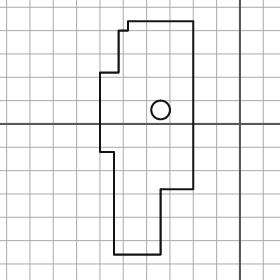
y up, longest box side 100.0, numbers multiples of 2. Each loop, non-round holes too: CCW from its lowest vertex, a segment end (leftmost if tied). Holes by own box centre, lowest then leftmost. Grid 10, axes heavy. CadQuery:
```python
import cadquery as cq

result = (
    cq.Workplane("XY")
    .moveTo(-54.0, -56.0)
    .lineTo(-34.0, -56.0)
    .lineTo(-34.0, -28.0)
    .lineTo(-20.0, -28.0)
    .lineTo(-20.0, 44.0)
    .lineTo(-48.0, 44.0)
    .lineTo(-48.0, 40.0)
    .lineTo(-52.0, 40.0)
    .lineTo(-52.0, 22.0)
    .lineTo(-60.0, 22.0)
    .lineTo(-60.0, -12.0)
    .lineTo(-54.0, -12.0)
    .close()
    .moveTo(-34.0, 6.0)
    .circle(4.0)
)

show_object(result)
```